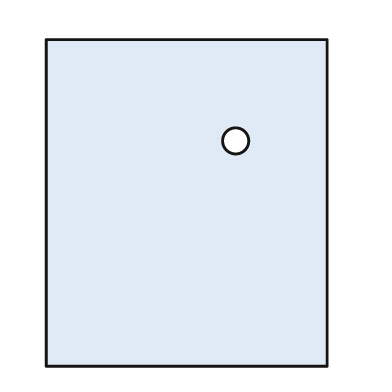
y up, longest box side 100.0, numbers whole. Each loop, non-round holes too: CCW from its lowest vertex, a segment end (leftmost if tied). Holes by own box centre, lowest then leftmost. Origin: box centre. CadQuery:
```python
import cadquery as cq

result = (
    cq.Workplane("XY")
    .moveTo(-43.0, -50.0)
    .lineTo(43.0, -50.0)
    .lineTo(43.0, 50.0)
    .lineTo(-43.0, 50.0)
    .close()
    .moveTo(15.0, 19.0)
    .circle(4.0)
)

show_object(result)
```